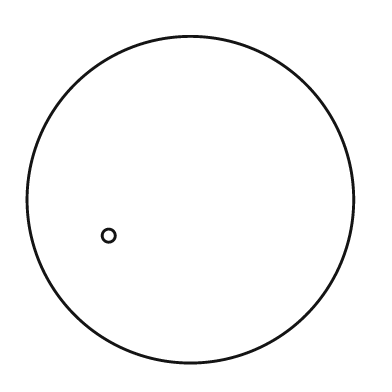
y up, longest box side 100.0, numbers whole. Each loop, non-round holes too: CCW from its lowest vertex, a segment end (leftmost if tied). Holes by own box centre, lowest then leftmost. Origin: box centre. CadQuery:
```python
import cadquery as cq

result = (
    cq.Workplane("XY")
    .moveTo(0.0, 0.0)
    .circle(50.0)
    .moveTo(-25.0, -11.0)
    .circle(2.0)
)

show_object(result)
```